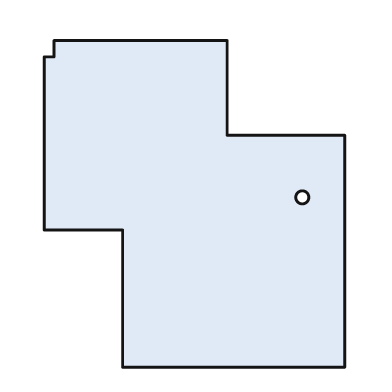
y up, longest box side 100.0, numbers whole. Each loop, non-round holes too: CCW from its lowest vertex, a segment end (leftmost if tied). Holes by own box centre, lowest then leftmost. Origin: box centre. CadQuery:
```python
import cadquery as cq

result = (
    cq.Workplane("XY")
    .moveTo(-22.0, -50.0)
    .lineTo(46.0, -50.0)
    .lineTo(46.0, 21.0)
    .lineTo(10.0, 21.0)
    .lineTo(10.0, 50.0)
    .lineTo(-43.0, 50.0)
    .lineTo(-43.0, 45.0)
    .lineTo(-46.0, 45.0)
    .lineTo(-46.0, -8.0)
    .lineTo(-22.0, -8.0)
    .close()
    .moveTo(33.0, 2.0)
    .circle(2.0)
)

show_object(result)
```